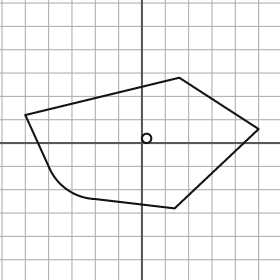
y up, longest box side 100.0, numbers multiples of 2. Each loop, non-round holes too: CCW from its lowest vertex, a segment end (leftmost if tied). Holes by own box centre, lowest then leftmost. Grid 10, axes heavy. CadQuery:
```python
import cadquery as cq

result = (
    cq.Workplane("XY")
    .moveTo(14.0, -28.0)
    .lineTo(50.0, 6.0)
    .lineTo(16.0, 28.0)
    .lineTo(-50.0, 12.0)
    .lineTo(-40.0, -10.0)
    .threePointArc((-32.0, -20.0), (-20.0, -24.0))
    .close()
    .moveTo(2.0, 2.0)
    .circle(2.0)
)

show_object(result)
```